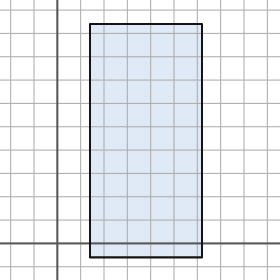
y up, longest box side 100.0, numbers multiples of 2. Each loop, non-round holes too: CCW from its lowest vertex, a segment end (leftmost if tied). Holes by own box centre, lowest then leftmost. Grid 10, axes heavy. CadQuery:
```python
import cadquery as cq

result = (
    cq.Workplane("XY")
    .moveTo(14.0, -6.0)
    .lineTo(62.0, -6.0)
    .lineTo(62.0, 94.0)
    .lineTo(14.0, 94.0)
    .close()
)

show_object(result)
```